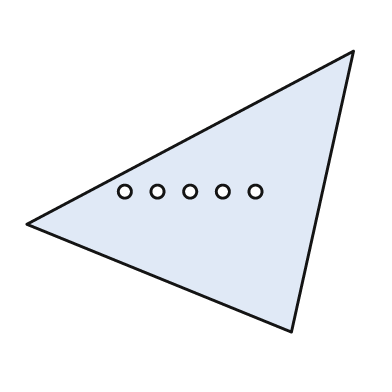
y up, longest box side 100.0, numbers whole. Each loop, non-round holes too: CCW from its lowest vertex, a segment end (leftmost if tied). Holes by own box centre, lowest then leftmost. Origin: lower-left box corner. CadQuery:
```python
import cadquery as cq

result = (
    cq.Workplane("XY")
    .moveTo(81.0, 0.0)
    .lineTo(100.0, 86.0)
    .lineTo(0.0, 33.0)
    .close()
    .moveTo(30.0, 43.0)
    .circle(2.0)
    .moveTo(40.0, 43.0)
    .circle(2.0)
    .moveTo(50.0, 43.0)
    .circle(2.0)
    .moveTo(60.0, 43.0)
    .circle(2.0)
    .moveTo(70.0, 43.0)
    .circle(2.0)
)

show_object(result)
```